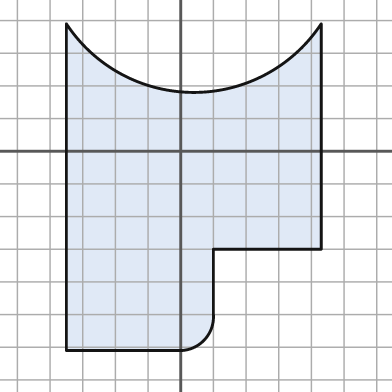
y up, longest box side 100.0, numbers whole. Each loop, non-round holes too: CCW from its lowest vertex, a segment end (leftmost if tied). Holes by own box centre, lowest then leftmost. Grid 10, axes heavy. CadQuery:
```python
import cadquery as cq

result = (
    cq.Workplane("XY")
    .moveTo(-35.0, -61.0)
    .lineTo(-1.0, -61.0)
    .threePointArc((7.0, -58.0), (10.0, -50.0))
    .lineTo(10.0, -30.0)
    .lineTo(43.0, -30.0)
    .lineTo(43.0, 39.0)
    .threePointArc((4.0, 18.0), (-35.0, 39.0))
    .close()
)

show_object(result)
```